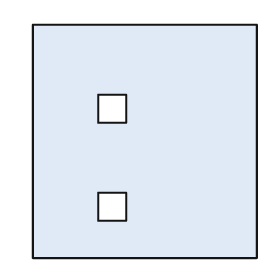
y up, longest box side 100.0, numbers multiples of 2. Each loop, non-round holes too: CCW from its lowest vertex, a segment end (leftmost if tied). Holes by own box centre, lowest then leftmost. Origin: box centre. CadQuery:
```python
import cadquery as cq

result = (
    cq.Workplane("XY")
    .moveTo(-48.0, -50.0)
    .lineTo(48.0, -50.0)
    .lineTo(48.0, 50.0)
    .lineTo(-48.0, 50.0)
    .close()
    .moveTo(-20.0, -34.0)
    .lineTo(-8.0, -34.0)
    .lineTo(-8.0, -22.0)
    .lineTo(-20.0, -22.0)
    .close()
    .moveTo(-20.0, 8.0)
    .lineTo(-8.0, 8.0)
    .lineTo(-8.0, 20.0)
    .lineTo(-20.0, 20.0)
    .close()
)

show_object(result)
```